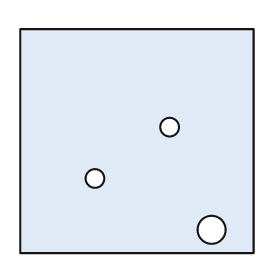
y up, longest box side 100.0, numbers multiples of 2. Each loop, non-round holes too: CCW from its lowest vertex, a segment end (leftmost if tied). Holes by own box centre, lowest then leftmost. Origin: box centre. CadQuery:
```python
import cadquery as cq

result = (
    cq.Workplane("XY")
    .moveTo(-50.0, -48.0)
    .lineTo(50.0, -48.0)
    .lineTo(50.0, 48.0)
    .lineTo(-50.0, 48.0)
    .close()
    .moveTo(32.0, -38.0)
    .circle(6.0)
    .moveTo(-18.0, -16.0)
    .circle(4.0)
    .moveTo(14.0, 6.0)
    .circle(4.0)
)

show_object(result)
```